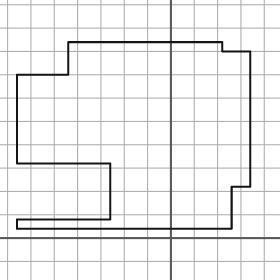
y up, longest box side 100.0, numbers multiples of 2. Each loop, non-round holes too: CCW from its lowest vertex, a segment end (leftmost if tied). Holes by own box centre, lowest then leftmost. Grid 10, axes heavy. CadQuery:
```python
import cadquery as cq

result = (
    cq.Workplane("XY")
    .moveTo(-66.0, 4.0)
    .lineTo(26.0, 4.0)
    .lineTo(26.0, 22.0)
    .lineTo(34.0, 22.0)
    .lineTo(34.0, 80.0)
    .lineTo(22.0, 80.0)
    .lineTo(22.0, 84.0)
    .lineTo(-44.0, 84.0)
    .lineTo(-44.0, 70.0)
    .lineTo(-66.0, 70.0)
    .lineTo(-66.0, 32.0)
    .lineTo(-26.0, 32.0)
    .lineTo(-26.0, 8.0)
    .lineTo(-66.0, 8.0)
    .close()
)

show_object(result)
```